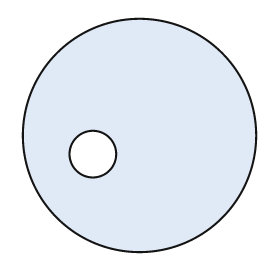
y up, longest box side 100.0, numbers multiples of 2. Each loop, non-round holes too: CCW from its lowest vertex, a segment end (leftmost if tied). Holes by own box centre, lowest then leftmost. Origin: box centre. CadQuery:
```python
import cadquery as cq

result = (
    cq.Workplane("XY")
    .moveTo(0.0, 0.0)
    .circle(50.0)
    .moveTo(-20.0, -8.0)
    .circle(10.0)
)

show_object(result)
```